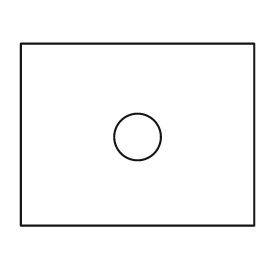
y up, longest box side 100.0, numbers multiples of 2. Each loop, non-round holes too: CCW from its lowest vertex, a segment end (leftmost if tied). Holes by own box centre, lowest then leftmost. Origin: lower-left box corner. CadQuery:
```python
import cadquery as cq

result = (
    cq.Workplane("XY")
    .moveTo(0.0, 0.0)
    .lineTo(100.0, 0.0)
    .lineTo(100.0, 78.0)
    .lineTo(0.0, 78.0)
    .close()
    .moveTo(50.0, 38.0)
    .circle(10.0)
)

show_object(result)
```